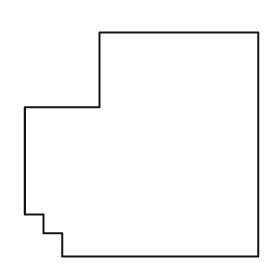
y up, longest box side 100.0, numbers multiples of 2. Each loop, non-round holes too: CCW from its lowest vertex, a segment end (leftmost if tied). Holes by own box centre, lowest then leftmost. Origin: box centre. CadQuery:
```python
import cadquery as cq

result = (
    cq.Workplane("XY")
    .moveTo(-34.0, -48.0)
    .lineTo(50.0, -48.0)
    .lineTo(50.0, 48.0)
    .lineTo(-18.0, 48.0)
    .lineTo(-18.0, 16.0)
    .lineTo(-50.0, 16.0)
    .lineTo(-50.0, -30.0)
    .lineTo(-42.0, -30.0)
    .lineTo(-42.0, -38.0)
    .lineTo(-34.0, -38.0)
    .close()
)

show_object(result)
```